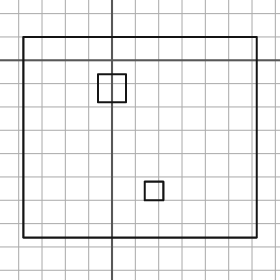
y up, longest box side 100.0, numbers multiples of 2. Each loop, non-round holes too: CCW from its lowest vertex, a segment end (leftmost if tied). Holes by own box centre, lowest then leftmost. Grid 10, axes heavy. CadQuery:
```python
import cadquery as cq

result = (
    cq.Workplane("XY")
    .moveTo(-38.0, -76.0)
    .lineTo(62.0, -76.0)
    .lineTo(62.0, 10.0)
    .lineTo(-38.0, 10.0)
    .close()
    .moveTo(14.0, -60.0)
    .lineTo(22.0, -60.0)
    .lineTo(22.0, -52.0)
    .lineTo(14.0, -52.0)
    .close()
    .moveTo(-6.0, -18.0)
    .lineTo(6.0, -18.0)
    .lineTo(6.0, -6.0)
    .lineTo(-6.0, -6.0)
    .close()
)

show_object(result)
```